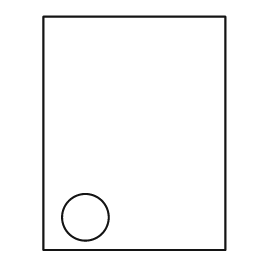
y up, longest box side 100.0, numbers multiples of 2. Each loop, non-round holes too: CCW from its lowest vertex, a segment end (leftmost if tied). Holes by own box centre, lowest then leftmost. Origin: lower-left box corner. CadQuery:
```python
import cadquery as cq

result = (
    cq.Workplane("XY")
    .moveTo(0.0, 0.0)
    .lineTo(78.0, 0.0)
    .lineTo(78.0, 100.0)
    .lineTo(0.0, 100.0)
    .close()
    .moveTo(18.0, 14.0)
    .circle(10.0)
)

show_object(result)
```